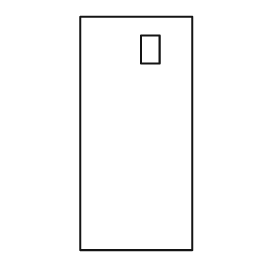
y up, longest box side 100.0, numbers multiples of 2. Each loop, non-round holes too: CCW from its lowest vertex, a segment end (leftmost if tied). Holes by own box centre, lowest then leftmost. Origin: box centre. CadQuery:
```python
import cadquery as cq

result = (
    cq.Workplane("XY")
    .moveTo(-24.0, -50.0)
    .lineTo(24.0, -50.0)
    .lineTo(24.0, 50.0)
    .lineTo(-24.0, 50.0)
    .close()
    .moveTo(2.0, 30.0)
    .lineTo(10.0, 30.0)
    .lineTo(10.0, 42.0)
    .lineTo(2.0, 42.0)
    .close()
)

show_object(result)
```